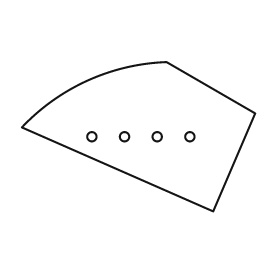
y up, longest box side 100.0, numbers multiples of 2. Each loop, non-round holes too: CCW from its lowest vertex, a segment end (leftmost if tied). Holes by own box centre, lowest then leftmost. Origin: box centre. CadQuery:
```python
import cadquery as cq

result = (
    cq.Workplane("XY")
    .moveTo(32.0, -32.0)
    .lineTo(50.0, 10.0)
    .lineTo(12.0, 32.0)
    .threePointArc((-22.0, 24.0), (-50.0, 4.0))
    .close()
    .moveTo(-20.0, 0.0)
    .circle(2.0)
    .moveTo(-6.0, 0.0)
    .circle(2.0)
    .moveTo(8.0, 0.0)
    .circle(2.0)
    .moveTo(22.0, 0.0)
    .circle(2.0)
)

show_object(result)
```